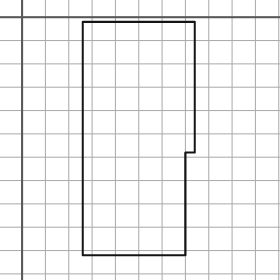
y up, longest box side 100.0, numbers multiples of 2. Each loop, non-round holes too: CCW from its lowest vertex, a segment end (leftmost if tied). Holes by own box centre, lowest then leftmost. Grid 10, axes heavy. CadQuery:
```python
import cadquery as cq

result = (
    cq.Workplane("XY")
    .moveTo(26.0, -102.0)
    .lineTo(70.0, -102.0)
    .lineTo(70.0, -58.0)
    .lineTo(74.0, -58.0)
    .lineTo(74.0, -2.0)
    .lineTo(26.0, -2.0)
    .close()
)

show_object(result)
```